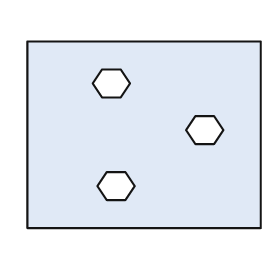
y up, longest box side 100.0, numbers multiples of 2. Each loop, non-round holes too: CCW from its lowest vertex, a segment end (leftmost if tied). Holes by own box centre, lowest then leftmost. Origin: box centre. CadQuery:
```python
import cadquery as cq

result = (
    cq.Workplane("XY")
    .moveTo(-50.0, -40.0)
    .lineTo(50.0, -40.0)
    .lineTo(50.0, 40.0)
    .lineTo(-50.0, 40.0)
    .close()
    .moveTo(-16.0, -28.0)
    .lineTo(-8.0, -28.0)
    .lineTo(-4.0, -22.0)
    .lineTo(-8.0, -16.0)
    .lineTo(-16.0, -16.0)
    .lineTo(-20.0, -22.0)
    .close()
    .moveTo(22.0, -4.0)
    .lineTo(30.0, -4.0)
    .lineTo(34.0, 2.0)
    .lineTo(30.0, 8.0)
    .lineTo(22.0, 8.0)
    .lineTo(18.0, 2.0)
    .close()
    .moveTo(-18.0, 16.0)
    .lineTo(-10.0, 16.0)
    .lineTo(-6.0, 22.0)
    .lineTo(-10.0, 28.0)
    .lineTo(-18.0, 28.0)
    .lineTo(-22.0, 22.0)
    .close()
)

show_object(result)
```